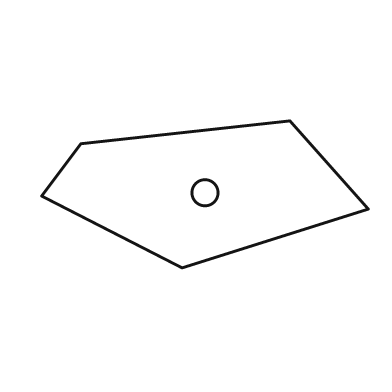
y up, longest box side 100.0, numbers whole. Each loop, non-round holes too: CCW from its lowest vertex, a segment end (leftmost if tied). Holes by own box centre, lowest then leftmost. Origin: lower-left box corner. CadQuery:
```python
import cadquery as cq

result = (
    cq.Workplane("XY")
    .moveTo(43.0, 0.0)
    .lineTo(100.0, 18.0)
    .lineTo(76.0, 45.0)
    .lineTo(12.0, 38.0)
    .lineTo(0.0, 22.0)
    .close()
    .moveTo(50.0, 23.0)
    .circle(4.0)
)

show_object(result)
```